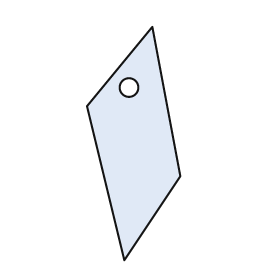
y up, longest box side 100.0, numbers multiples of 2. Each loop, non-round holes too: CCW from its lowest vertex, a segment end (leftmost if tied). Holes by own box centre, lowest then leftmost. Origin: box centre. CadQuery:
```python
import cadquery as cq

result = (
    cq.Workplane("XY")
    .moveTo(-4.0, -50.0)
    .lineTo(20.0, -14.0)
    .lineTo(8.0, 50.0)
    .lineTo(-20.0, 16.0)
    .close()
    .moveTo(-2.0, 24.0)
    .circle(4.0)
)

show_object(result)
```